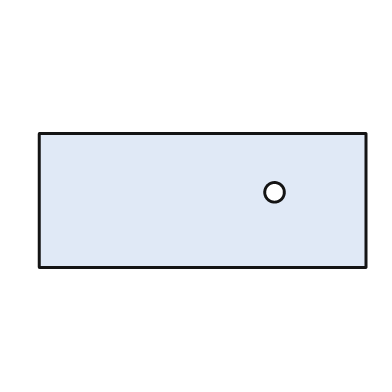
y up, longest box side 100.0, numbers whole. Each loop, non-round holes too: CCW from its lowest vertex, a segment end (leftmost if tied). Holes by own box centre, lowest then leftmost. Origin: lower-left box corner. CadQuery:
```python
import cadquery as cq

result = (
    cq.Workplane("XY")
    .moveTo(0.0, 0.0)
    .lineTo(100.0, 0.0)
    .lineTo(100.0, 41.0)
    .lineTo(0.0, 41.0)
    .close()
    .moveTo(72.0, 23.0)
    .circle(3.0)
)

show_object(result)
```